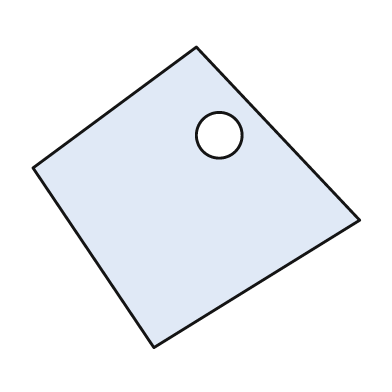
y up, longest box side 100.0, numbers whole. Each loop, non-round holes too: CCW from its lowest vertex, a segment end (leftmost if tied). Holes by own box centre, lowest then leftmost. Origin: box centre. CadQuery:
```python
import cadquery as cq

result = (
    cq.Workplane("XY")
    .moveTo(-13.0, -46.0)
    .lineTo(50.0, -7.0)
    .lineTo(0.0, 46.0)
    .lineTo(-50.0, 9.0)
    .close()
    .moveTo(7.0, 19.0)
    .circle(7.0)
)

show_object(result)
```